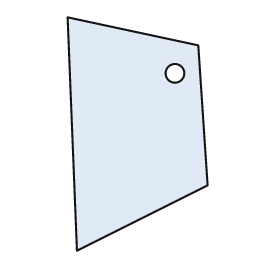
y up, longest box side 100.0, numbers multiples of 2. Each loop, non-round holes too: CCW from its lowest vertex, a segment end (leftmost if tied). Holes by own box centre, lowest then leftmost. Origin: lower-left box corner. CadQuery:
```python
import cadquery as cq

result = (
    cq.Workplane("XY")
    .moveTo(4.0, 0.0)
    .lineTo(60.0, 28.0)
    .lineTo(56.0, 88.0)
    .lineTo(0.0, 100.0)
    .close()
    .moveTo(46.0, 76.0)
    .circle(4.0)
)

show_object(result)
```